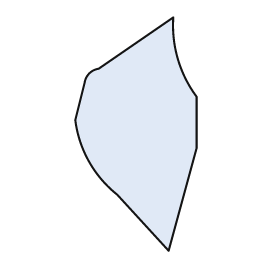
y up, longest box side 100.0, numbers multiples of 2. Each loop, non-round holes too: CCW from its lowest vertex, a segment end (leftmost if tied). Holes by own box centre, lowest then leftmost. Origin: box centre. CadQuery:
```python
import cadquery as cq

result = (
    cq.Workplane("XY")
    .moveTo(14.0, -50.0)
    .lineTo(26.0, -6.0)
    .lineTo(26.0, 16.0)
    .threePointArc((18.0, 32.0), (16.0, 50.0))
    .lineTo(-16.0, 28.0)
    .threePointArc((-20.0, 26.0), (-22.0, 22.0))
    .lineTo(-26.0, 6.0)
    .threePointArc((-20.0, -12.0), (-8.0, -26.0))
    .close()
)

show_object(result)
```